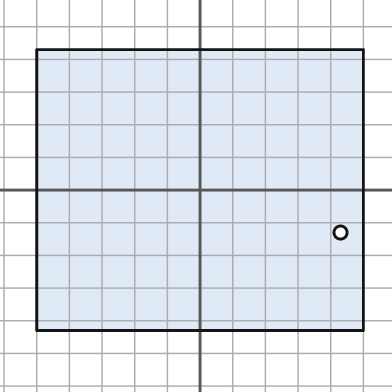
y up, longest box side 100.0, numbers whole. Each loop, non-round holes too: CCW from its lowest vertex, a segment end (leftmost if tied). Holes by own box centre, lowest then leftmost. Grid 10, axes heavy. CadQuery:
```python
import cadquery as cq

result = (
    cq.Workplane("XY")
    .moveTo(-50.0, -43.0)
    .lineTo(50.0, -43.0)
    .lineTo(50.0, 43.0)
    .lineTo(-50.0, 43.0)
    .close()
    .moveTo(43.0, -13.0)
    .circle(2.0)
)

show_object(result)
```